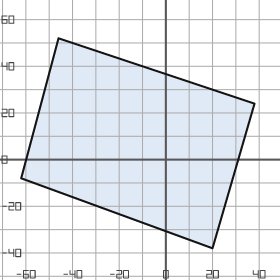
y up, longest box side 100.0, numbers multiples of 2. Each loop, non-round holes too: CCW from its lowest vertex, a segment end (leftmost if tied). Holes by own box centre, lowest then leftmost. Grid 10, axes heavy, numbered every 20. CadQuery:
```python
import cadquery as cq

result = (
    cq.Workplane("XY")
    .moveTo(20.0, -38.0)
    .lineTo(38.0, 24.0)
    .lineTo(-46.0, 52.0)
    .lineTo(-62.0, -8.0)
    .close()
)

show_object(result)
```